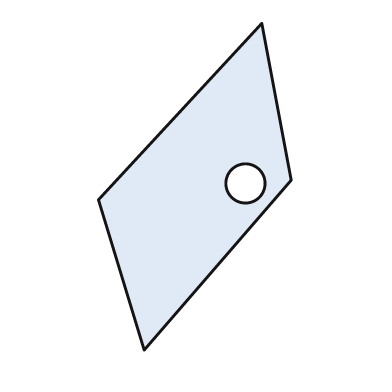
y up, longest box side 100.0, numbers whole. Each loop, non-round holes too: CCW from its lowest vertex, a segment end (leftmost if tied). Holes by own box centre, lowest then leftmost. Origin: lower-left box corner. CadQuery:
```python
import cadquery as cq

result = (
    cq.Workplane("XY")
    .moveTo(14.0, 0.0)
    .lineTo(59.0, 52.0)
    .lineTo(50.0, 100.0)
    .lineTo(0.0, 46.0)
    .close()
    .moveTo(45.0, 51.0)
    .circle(6.0)
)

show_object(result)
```